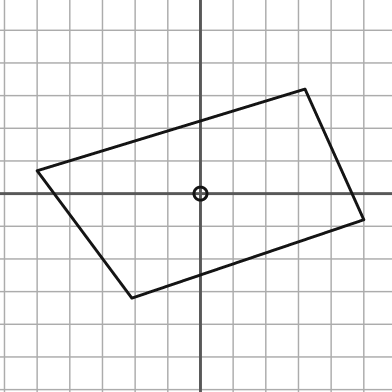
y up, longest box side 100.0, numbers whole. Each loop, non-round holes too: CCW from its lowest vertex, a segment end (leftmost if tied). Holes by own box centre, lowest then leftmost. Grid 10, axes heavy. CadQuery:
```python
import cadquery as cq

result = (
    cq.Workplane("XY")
    .moveTo(-21.0, -32.0)
    .lineTo(50.0, -8.0)
    .lineTo(32.0, 32.0)
    .lineTo(-50.0, 7.0)
    .close()
    .moveTo(0.0, 0.0)
    .circle(2.0)
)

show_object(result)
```